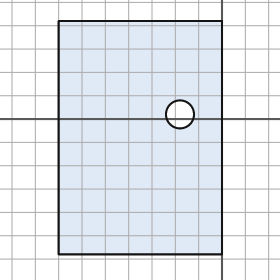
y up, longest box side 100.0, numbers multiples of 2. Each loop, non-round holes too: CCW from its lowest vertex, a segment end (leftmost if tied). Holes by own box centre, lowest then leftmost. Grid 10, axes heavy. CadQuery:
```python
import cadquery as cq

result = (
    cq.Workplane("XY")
    .moveTo(-70.0, -58.0)
    .lineTo(0.0, -58.0)
    .lineTo(0.0, 42.0)
    .lineTo(-70.0, 42.0)
    .close()
    .moveTo(-18.0, 2.0)
    .circle(6.0)
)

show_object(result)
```